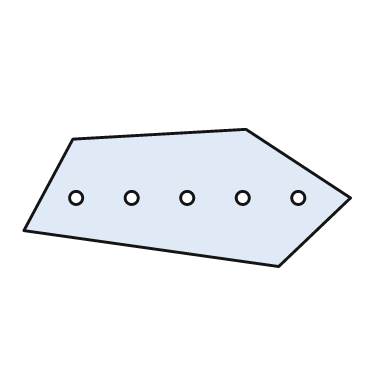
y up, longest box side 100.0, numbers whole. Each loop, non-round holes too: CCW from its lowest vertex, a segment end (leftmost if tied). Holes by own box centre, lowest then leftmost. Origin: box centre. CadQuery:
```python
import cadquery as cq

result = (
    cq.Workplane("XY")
    .moveTo(28.0, -21.0)
    .lineTo(50.0, 0.0)
    .lineTo(18.0, 21.0)
    .lineTo(-35.0, 18.0)
    .lineTo(-50.0, -10.0)
    .close()
    .moveTo(-34.0, 0.0)
    .circle(2.0)
    .moveTo(-17.0, 0.0)
    .circle(2.0)
    .moveTo(0.0, 0.0)
    .circle(2.0)
    .moveTo(17.0, 0.0)
    .circle(2.0)
    .moveTo(34.0, 0.0)
    .circle(2.0)
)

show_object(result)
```